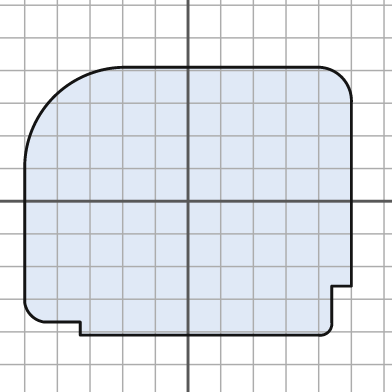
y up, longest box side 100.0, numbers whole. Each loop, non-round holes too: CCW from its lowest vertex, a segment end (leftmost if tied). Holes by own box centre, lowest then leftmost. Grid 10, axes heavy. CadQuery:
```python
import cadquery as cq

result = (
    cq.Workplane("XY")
    .moveTo(-33.0, -41.0)
    .lineTo(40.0, -41.0)
    .threePointArc((43.0, -40.0), (44.0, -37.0))
    .lineTo(44.0, -26.0)
    .lineTo(50.0, -26.0)
    .lineTo(50.0, 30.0)
    .threePointArc((47.0, 38.0), (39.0, 41.0))
    .lineTo(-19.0, 41.0)
    .threePointArc((-41.0, 32.0), (-50.0, 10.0))
    .lineTo(-50.0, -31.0)
    .threePointArc((-48.0, -35.0), (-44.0, -37.0))
    .lineTo(-33.0, -37.0)
    .close()
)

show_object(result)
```